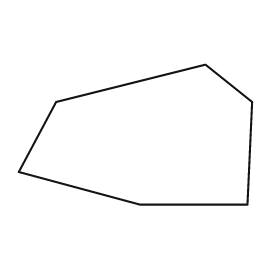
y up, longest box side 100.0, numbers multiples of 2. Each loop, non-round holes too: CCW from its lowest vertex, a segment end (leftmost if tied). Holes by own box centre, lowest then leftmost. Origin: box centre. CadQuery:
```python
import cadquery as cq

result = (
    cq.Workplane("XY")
    .moveTo(2.0, -30.0)
    .lineTo(48.0, -30.0)
    .lineTo(50.0, 14.0)
    .lineTo(30.0, 30.0)
    .lineTo(-34.0, 14.0)
    .lineTo(-50.0, -16.0)
    .close()
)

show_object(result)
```